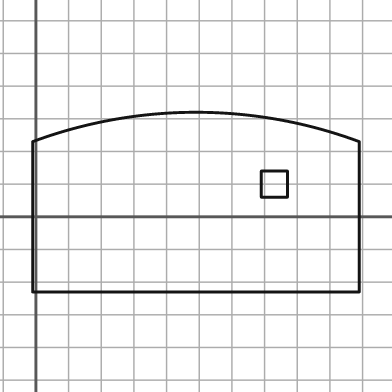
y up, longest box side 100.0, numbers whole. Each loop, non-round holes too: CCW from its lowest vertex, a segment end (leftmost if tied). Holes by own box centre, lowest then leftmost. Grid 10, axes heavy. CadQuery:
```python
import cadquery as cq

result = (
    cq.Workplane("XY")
    .moveTo(-1.0, -23.0)
    .lineTo(99.0, -23.0)
    .lineTo(99.0, 23.0)
    .threePointArc((49.0, 32.0), (-1.0, 23.0))
    .close()
    .moveTo(69.0, 6.0)
    .lineTo(77.0, 6.0)
    .lineTo(77.0, 14.0)
    .lineTo(69.0, 14.0)
    .close()
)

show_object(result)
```